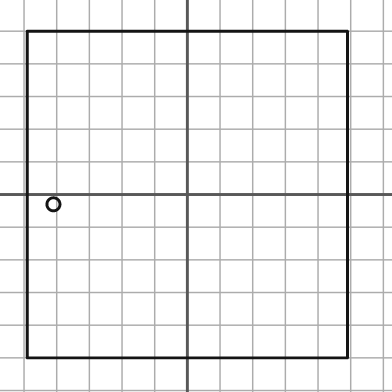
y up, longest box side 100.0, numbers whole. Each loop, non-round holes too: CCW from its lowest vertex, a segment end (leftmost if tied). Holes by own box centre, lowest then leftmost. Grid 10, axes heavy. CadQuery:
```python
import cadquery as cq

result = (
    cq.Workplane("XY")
    .moveTo(-49.0, -50.0)
    .lineTo(49.0, -50.0)
    .lineTo(49.0, 50.0)
    .lineTo(-49.0, 50.0)
    .close()
    .moveTo(-41.0, -3.0)
    .circle(2.0)
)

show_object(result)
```